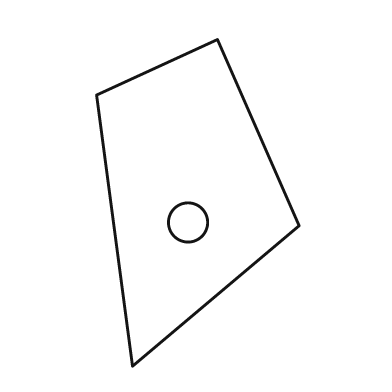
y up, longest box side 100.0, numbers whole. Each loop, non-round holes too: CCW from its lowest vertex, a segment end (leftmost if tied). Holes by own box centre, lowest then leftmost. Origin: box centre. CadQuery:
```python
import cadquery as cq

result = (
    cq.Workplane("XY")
    .moveTo(-20.0, -50.0)
    .lineTo(31.0, -7.0)
    .lineTo(6.0, 50.0)
    .lineTo(-31.0, 33.0)
    .close()
    .moveTo(-3.0, -6.0)
    .circle(6.0)
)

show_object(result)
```